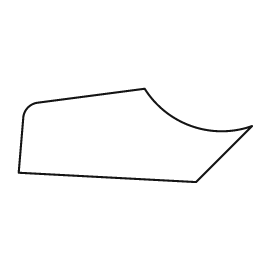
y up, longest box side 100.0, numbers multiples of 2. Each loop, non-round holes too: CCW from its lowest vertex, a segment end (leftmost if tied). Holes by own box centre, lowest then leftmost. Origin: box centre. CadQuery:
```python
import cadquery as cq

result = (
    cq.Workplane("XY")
    .moveTo(26.0, -20.0)
    .lineTo(50.0, 4.0)
    .threePointArc((24.0, 4.0), (4.0, 20.0))
    .lineTo(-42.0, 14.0)
    .threePointArc((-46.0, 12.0), (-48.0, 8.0))
    .lineTo(-50.0, -16.0)
    .close()
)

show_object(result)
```